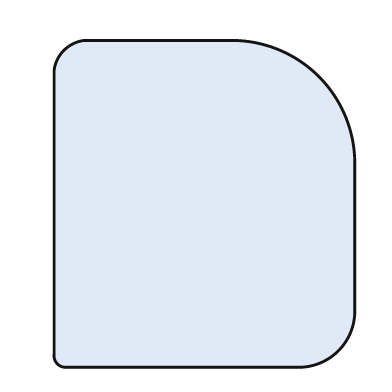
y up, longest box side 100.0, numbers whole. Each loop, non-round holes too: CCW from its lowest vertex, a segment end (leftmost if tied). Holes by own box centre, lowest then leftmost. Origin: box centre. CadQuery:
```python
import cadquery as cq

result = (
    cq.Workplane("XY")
    .moveTo(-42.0, -50.0)
    .lineTo(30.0, -50.0)
    .threePointArc((41.0, -45.0), (46.0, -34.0))
    .lineTo(46.0, 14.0)
    .threePointArc((35.0, 39.0), (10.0, 50.0))
    .lineTo(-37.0, 50.0)
    .threePointArc((-43.0, 47.0), (-46.0, 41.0))
    .lineTo(-46.0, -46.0)
    .threePointArc((-45.0, -49.0), (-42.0, -50.0))
    .close()
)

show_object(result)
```